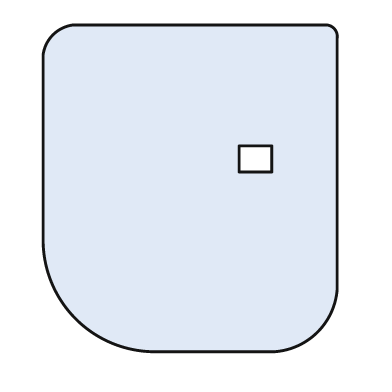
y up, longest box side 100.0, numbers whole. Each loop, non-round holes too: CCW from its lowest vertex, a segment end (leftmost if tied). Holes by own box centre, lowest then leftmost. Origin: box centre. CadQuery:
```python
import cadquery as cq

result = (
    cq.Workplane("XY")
    .moveTo(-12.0, -50.0)
    .lineTo(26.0, -50.0)
    .threePointArc((39.0, -44.0), (45.0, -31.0))
    .lineTo(45.0, 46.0)
    .threePointArc((44.0, 49.0), (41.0, 50.0))
    .lineTo(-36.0, 50.0)
    .threePointArc((-42.0, 47.0), (-45.0, 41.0))
    .lineTo(-45.0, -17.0)
    .threePointArc((-35.0, -40.0), (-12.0, -50.0))
    .close()
    .moveTo(15.0, 5.0)
    .lineTo(25.0, 5.0)
    .lineTo(25.0, 13.0)
    .lineTo(15.0, 13.0)
    .close()
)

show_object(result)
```